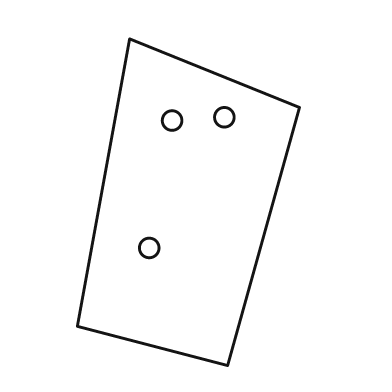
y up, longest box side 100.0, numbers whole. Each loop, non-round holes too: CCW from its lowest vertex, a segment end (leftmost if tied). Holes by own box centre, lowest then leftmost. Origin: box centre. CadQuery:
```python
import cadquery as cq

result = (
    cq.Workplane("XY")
    .moveTo(12.0, -50.0)
    .lineTo(34.0, 29.0)
    .lineTo(-18.0, 50.0)
    .lineTo(-34.0, -38.0)
    .close()
    .moveTo(-12.0, -14.0)
    .circle(3.0)
    .moveTo(-5.0, 25.0)
    .circle(3.0)
    .moveTo(11.0, 26.0)
    .circle(3.0)
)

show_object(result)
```